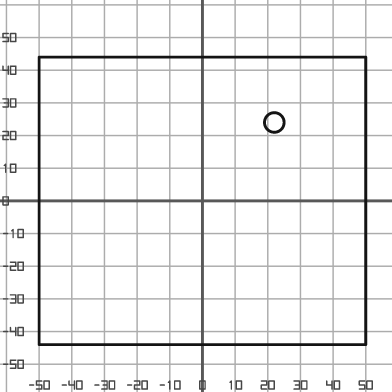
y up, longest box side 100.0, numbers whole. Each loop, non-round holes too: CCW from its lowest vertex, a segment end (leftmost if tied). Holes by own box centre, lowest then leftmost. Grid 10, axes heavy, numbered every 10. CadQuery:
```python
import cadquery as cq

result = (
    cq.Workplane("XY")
    .moveTo(-50.0, -44.0)
    .lineTo(50.0, -44.0)
    .lineTo(50.0, 44.0)
    .lineTo(-50.0, 44.0)
    .close()
    .moveTo(22.0, 24.0)
    .circle(3.0)
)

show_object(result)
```